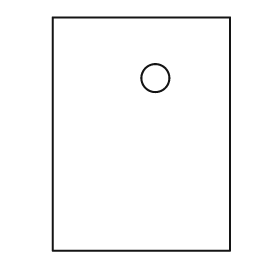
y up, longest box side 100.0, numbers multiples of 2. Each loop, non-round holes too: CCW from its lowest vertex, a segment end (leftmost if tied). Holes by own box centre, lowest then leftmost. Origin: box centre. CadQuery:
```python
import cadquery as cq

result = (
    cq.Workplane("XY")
    .moveTo(-38.0, -50.0)
    .lineTo(38.0, -50.0)
    .lineTo(38.0, 50.0)
    .lineTo(-38.0, 50.0)
    .close()
    .moveTo(6.0, 24.0)
    .circle(6.0)
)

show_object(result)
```